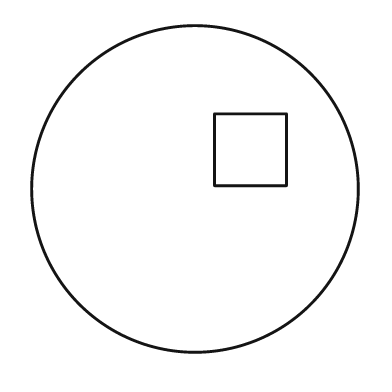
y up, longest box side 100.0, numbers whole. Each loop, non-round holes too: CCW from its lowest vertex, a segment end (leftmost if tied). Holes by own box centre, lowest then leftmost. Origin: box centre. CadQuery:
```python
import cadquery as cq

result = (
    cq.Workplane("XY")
    .moveTo(0.0, 0.0)
    .circle(50.0)
    .moveTo(6.0, 1.0)
    .lineTo(28.0, 1.0)
    .lineTo(28.0, 23.0)
    .lineTo(6.0, 23.0)
    .close()
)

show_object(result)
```